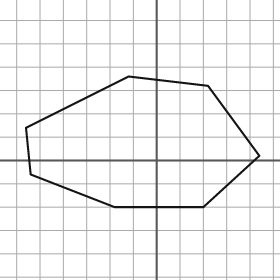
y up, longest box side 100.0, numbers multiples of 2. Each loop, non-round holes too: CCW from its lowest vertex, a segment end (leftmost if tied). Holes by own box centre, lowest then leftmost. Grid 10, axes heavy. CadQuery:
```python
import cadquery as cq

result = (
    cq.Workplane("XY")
    .moveTo(-18.0, -20.0)
    .lineTo(20.0, -20.0)
    .lineTo(44.0, 2.0)
    .lineTo(22.0, 32.0)
    .lineTo(-12.0, 36.0)
    .lineTo(-56.0, 14.0)
    .lineTo(-54.0, -6.0)
    .close()
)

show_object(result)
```